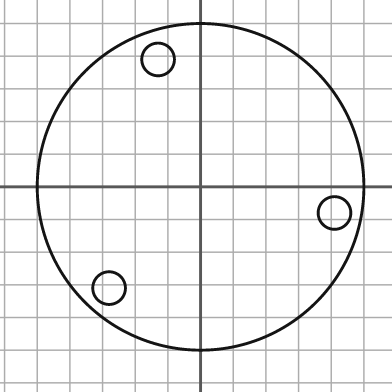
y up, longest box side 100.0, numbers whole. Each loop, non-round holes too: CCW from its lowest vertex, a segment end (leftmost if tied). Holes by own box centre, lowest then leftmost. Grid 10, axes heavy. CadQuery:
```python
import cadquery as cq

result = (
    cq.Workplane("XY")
    .moveTo(0.0, 0.0)
    .circle(50.0)
    .moveTo(-28.0, -31.0)
    .circle(5.0)
    .moveTo(41.0, -8.0)
    .circle(5.0)
    .moveTo(-13.0, 39.0)
    .circle(5.0)
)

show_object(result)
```